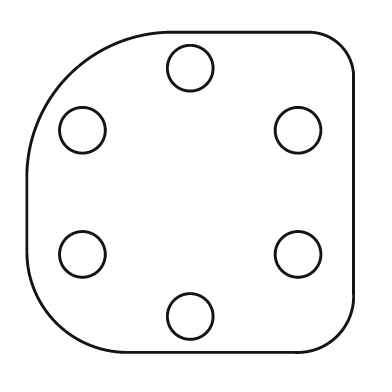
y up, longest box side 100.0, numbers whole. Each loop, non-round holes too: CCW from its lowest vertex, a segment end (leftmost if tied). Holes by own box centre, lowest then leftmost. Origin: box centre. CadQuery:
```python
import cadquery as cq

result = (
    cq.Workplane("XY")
    .moveTo(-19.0, -49.0)
    .lineTo(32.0, -49.0)
    .threePointArc((45.0, -44.0), (50.0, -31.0))
    .lineTo(50.0, 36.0)
    .threePointArc((46.0, 45.0), (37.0, 49.0))
    .lineTo(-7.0, 49.0)
    .threePointArc((-37.0, 36.0), (-50.0, 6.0))
    .lineTo(-50.0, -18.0)
    .threePointArc((-41.0, -40.0), (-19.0, -49.0))
    .close()
    .moveTo(0.0, -38.0)
    .circle(7.0)
    .moveTo(-33.0, -19.0)
    .circle(7.0)
    .moveTo(33.0, -19.0)
    .circle(7.0)
    .moveTo(-33.0, 19.0)
    .circle(7.0)
    .moveTo(33.0, 19.0)
    .circle(7.0)
    .moveTo(0.0, 38.0)
    .circle(7.0)
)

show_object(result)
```